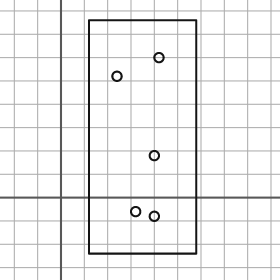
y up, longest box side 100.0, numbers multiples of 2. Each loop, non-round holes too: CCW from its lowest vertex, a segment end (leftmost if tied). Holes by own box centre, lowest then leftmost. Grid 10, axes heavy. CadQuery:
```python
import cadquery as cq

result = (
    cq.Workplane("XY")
    .moveTo(12.0, -24.0)
    .lineTo(58.0, -24.0)
    .lineTo(58.0, 76.0)
    .lineTo(12.0, 76.0)
    .close()
    .moveTo(40.0, -8.0)
    .circle(2.0)
    .moveTo(32.0, -6.0)
    .circle(2.0)
    .moveTo(40.0, 18.0)
    .circle(2.0)
    .moveTo(24.0, 52.0)
    .circle(2.0)
    .moveTo(42.0, 60.0)
    .circle(2.0)
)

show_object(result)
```